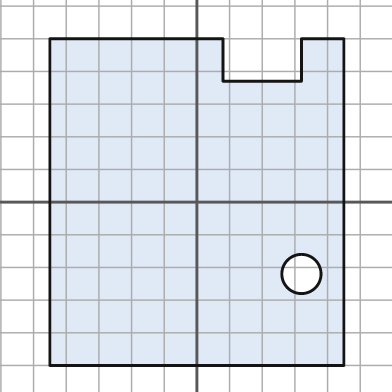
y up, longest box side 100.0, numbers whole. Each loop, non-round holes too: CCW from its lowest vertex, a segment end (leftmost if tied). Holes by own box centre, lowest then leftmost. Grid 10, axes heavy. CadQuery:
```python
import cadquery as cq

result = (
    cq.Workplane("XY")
    .moveTo(-45.0, -50.0)
    .lineTo(45.0, -50.0)
    .lineTo(45.0, 50.0)
    .lineTo(32.0, 50.0)
    .lineTo(32.0, 37.0)
    .lineTo(8.0, 37.0)
    .lineTo(8.0, 50.0)
    .lineTo(-45.0, 50.0)
    .close()
    .moveTo(32.0, -22.0)
    .circle(6.0)
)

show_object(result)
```